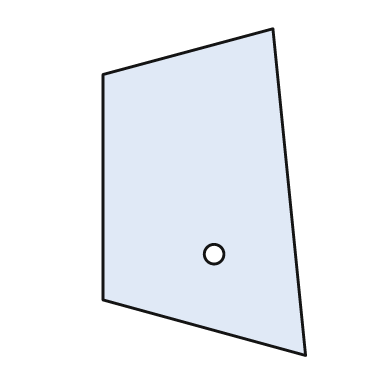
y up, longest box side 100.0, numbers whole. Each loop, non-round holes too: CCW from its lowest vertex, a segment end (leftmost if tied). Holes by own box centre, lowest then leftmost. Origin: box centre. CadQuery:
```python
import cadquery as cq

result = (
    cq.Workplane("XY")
    .moveTo(31.0, -50.0)
    .lineTo(21.0, 50.0)
    .lineTo(-31.0, 36.0)
    .lineTo(-31.0, -33.0)
    .close()
    .moveTo(3.0, -19.0)
    .circle(3.0)
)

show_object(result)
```